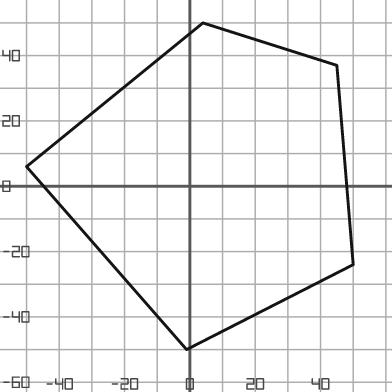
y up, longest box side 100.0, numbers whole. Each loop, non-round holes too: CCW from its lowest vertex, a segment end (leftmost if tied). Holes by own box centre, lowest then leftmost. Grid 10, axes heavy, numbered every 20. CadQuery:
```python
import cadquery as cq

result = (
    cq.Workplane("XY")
    .moveTo(-1.0, -50.0)
    .lineTo(50.0, -24.0)
    .lineTo(45.0, 37.0)
    .lineTo(4.0, 50.0)
    .lineTo(-50.0, 6.0)
    .close()
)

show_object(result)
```